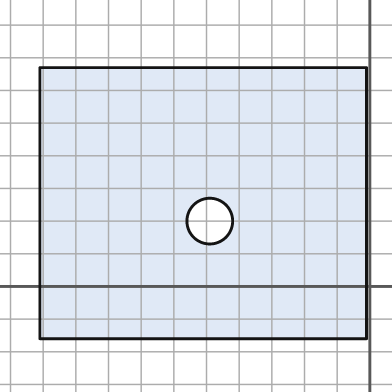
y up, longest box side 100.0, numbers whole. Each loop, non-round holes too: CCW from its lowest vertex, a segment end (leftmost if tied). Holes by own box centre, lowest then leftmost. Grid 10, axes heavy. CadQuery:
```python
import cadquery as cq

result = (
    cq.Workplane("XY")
    .moveTo(-101.0, -16.0)
    .lineTo(-1.0, -16.0)
    .lineTo(-1.0, 67.0)
    .lineTo(-101.0, 67.0)
    .close()
    .moveTo(-49.0, 20.0)
    .circle(7.0)
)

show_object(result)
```